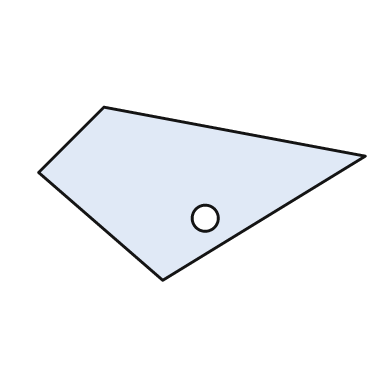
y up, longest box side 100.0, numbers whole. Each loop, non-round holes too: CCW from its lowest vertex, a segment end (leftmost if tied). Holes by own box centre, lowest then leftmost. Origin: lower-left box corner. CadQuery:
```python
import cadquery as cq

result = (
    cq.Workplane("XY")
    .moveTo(38.0, 0.0)
    .lineTo(100.0, 38.0)
    .lineTo(20.0, 53.0)
    .lineTo(0.0, 33.0)
    .close()
    .moveTo(51.0, 19.0)
    .circle(4.0)
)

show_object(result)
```